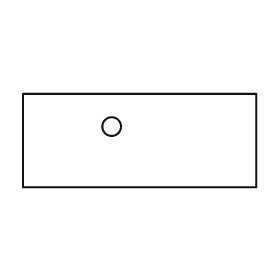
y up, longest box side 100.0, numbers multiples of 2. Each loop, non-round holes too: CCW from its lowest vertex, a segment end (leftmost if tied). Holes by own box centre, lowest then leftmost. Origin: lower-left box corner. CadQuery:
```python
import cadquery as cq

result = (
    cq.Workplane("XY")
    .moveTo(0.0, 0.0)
    .lineTo(100.0, 0.0)
    .lineTo(100.0, 40.0)
    .lineTo(0.0, 40.0)
    .close()
    .moveTo(38.0, 26.0)
    .circle(4.0)
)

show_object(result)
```